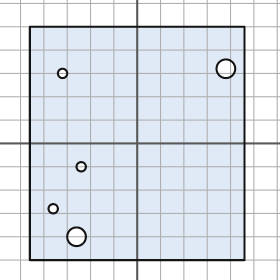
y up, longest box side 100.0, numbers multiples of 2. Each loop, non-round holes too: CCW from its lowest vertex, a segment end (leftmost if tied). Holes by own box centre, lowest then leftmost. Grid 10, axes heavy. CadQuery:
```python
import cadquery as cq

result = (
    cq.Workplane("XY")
    .moveTo(-46.0, -50.0)
    .lineTo(46.0, -50.0)
    .lineTo(46.0, 50.0)
    .lineTo(-46.0, 50.0)
    .close()
    .moveTo(-26.0, -40.0)
    .circle(4.0)
    .moveTo(-36.0, -28.0)
    .circle(2.0)
    .moveTo(-24.0, -10.0)
    .circle(2.0)
    .moveTo(-32.0, 30.0)
    .circle(2.0)
    .moveTo(38.0, 32.0)
    .circle(4.0)
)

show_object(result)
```